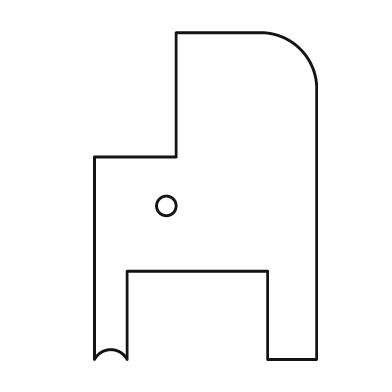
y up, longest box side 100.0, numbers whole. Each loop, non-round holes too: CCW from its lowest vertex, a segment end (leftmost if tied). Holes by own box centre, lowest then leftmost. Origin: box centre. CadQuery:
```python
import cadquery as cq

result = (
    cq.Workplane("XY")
    .moveTo(-34.0, -50.0)
    .threePointArc((-29.0, -47.0), (-24.0, -50.0))
    .lineTo(-24.0, -23.0)
    .lineTo(19.0, -23.0)
    .lineTo(19.0, -50.0)
    .lineTo(34.0, -50.0)
    .lineTo(34.0, 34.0)
    .threePointArc((29.0, 45.0), (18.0, 50.0))
    .lineTo(-9.0, 50.0)
    .lineTo(-9.0, 12.0)
    .lineTo(-34.0, 12.0)
    .close()
    .moveTo(-12.0, -3.0)
    .circle(3.0)
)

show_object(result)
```